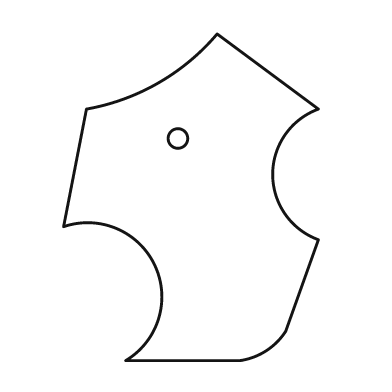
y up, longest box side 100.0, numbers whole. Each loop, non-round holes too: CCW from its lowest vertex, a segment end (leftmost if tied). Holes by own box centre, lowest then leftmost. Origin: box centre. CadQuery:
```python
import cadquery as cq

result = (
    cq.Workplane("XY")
    .moveTo(-20.0, -50.0)
    .lineTo(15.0, -50.0)
    .threePointArc((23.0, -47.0), (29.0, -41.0))
    .lineTo(39.0, -13.0)
    .threePointArc((25.0, 7.0), (39.0, 27.0))
    .lineTo(8.0, 50.0)
    .threePointArc((-10.0, 35.0), (-32.0, 27.0))
    .lineTo(-39.0, -9.0)
    .threePointArc((-11.0, -21.0), (-20.0, -50.0))
    .close()
    .moveTo(-4.0, 18.0)
    .circle(3.0)
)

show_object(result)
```